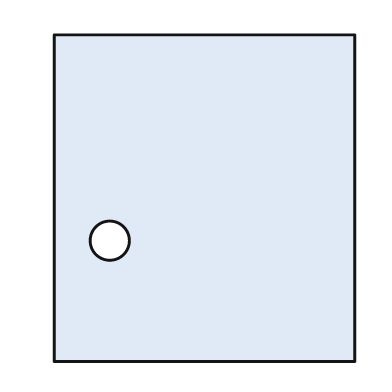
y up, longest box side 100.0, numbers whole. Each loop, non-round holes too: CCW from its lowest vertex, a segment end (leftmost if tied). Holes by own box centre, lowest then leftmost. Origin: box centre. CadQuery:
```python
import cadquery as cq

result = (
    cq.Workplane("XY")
    .moveTo(-46.0, -50.0)
    .lineTo(46.0, -50.0)
    .lineTo(46.0, 50.0)
    .lineTo(-46.0, 50.0)
    .close()
    .moveTo(-29.0, -13.0)
    .circle(6.0)
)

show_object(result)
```